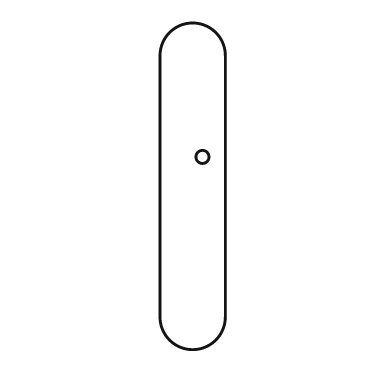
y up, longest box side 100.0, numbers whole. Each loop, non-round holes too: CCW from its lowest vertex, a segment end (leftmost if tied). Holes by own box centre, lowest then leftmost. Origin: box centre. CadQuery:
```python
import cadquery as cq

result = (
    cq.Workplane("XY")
    .moveTo(-10.0, -40.0)
    .threePointArc((0.0, -50.0), (10.0, -40.0))
    .lineTo(10.0, 40.0)
    .threePointArc((0.0, 50.0), (-10.0, 40.0))
    .close()
    .moveTo(3.0, 9.0)
    .circle(2.0)
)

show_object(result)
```